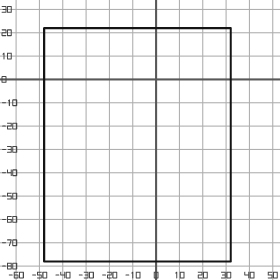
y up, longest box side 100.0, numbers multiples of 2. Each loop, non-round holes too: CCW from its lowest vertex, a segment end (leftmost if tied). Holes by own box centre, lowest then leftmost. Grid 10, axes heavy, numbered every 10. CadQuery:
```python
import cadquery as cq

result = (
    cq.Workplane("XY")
    .moveTo(-48.0, -78.0)
    .lineTo(32.0, -78.0)
    .lineTo(32.0, 22.0)
    .lineTo(-48.0, 22.0)
    .close()
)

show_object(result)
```